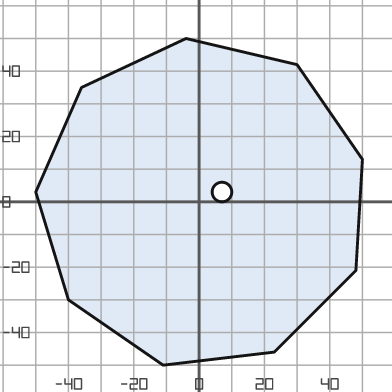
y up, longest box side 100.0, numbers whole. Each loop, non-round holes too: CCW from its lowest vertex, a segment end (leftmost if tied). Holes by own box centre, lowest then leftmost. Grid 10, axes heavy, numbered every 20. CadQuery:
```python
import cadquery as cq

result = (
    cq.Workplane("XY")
    .moveTo(-11.0, -50.0)
    .lineTo(23.0, -46.0)
    .lineTo(48.0, -21.0)
    .lineTo(50.0, 13.0)
    .lineTo(30.0, 42.0)
    .lineTo(-4.0, 50.0)
    .lineTo(-36.0, 35.0)
    .lineTo(-50.0, 3.0)
    .lineTo(-40.0, -30.0)
    .close()
    .moveTo(7.0, 3.0)
    .circle(3.0)
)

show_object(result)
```